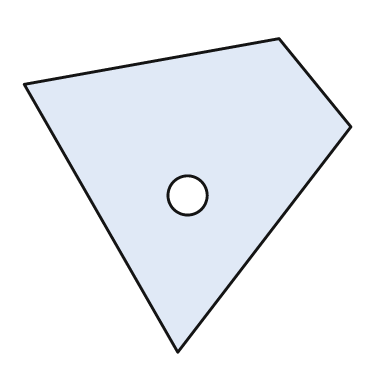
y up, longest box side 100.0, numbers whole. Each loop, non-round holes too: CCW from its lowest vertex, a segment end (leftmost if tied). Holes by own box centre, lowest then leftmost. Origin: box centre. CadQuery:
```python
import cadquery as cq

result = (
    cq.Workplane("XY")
    .moveTo(-3.0, -48.0)
    .lineTo(50.0, 21.0)
    .lineTo(28.0, 48.0)
    .lineTo(-50.0, 34.0)
    .close()
    .moveTo(0.0, 0.0)
    .circle(6.0)
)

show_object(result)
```